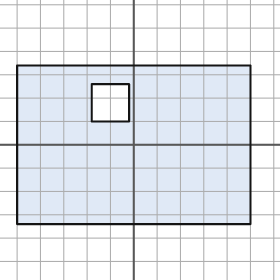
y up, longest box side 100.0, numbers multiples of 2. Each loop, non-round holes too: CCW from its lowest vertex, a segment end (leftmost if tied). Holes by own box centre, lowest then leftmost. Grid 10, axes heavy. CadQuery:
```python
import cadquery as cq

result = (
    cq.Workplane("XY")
    .moveTo(-50.0, -34.0)
    .lineTo(50.0, -34.0)
    .lineTo(50.0, 34.0)
    .lineTo(-50.0, 34.0)
    .close()
    .moveTo(-18.0, 10.0)
    .lineTo(-2.0, 10.0)
    .lineTo(-2.0, 26.0)
    .lineTo(-18.0, 26.0)
    .close()
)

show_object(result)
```